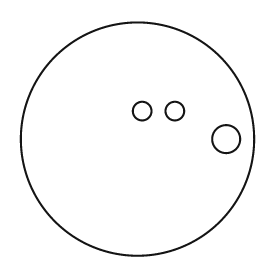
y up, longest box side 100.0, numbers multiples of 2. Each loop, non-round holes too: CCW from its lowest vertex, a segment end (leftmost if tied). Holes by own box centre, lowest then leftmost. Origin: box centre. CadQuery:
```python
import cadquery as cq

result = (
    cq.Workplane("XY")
    .moveTo(0.0, 0.0)
    .circle(50.0)
    .moveTo(38.0, 0.0)
    .circle(6.0)
    .moveTo(2.0, 12.0)
    .circle(4.0)
    .moveTo(16.0, 12.0)
    .circle(4.0)
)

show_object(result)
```